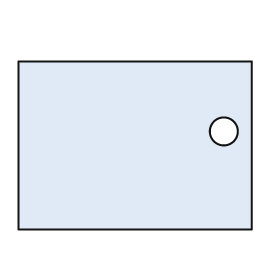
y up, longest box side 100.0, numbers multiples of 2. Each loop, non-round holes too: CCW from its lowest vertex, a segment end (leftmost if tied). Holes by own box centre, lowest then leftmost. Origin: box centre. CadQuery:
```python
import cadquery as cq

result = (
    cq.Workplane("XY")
    .moveTo(-50.0, -36.0)
    .lineTo(50.0, -36.0)
    .lineTo(50.0, 36.0)
    .lineTo(-50.0, 36.0)
    .close()
    .moveTo(38.0, 6.0)
    .circle(6.0)
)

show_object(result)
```